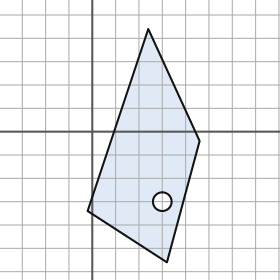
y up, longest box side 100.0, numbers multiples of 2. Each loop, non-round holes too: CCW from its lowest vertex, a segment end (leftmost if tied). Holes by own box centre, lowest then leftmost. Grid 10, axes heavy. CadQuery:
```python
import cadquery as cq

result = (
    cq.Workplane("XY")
    .moveTo(32.0, -56.0)
    .lineTo(46.0, -4.0)
    .lineTo(24.0, 44.0)
    .lineTo(-2.0, -34.0)
    .close()
    .moveTo(30.0, -30.0)
    .circle(4.0)
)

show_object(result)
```